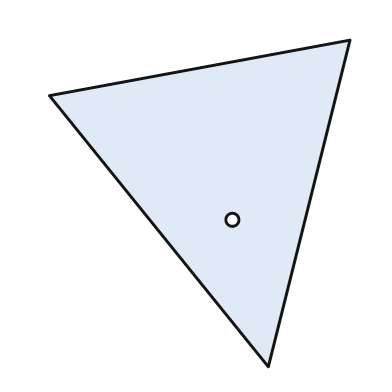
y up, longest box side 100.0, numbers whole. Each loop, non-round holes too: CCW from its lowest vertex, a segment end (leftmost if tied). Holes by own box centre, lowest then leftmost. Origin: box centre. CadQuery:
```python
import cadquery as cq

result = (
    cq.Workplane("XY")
    .moveTo(21.0, -50.0)
    .lineTo(46.0, 50.0)
    .lineTo(-46.0, 33.0)
    .close()
    .moveTo(10.0, -5.0)
    .circle(2.0)
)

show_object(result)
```